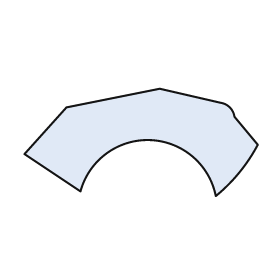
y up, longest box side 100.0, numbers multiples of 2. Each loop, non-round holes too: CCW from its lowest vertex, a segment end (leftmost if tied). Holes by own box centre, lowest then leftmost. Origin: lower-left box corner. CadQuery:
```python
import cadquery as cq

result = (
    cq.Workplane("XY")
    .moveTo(82.0, 0.0)
    .threePointArc((92.0, 10.0), (100.0, 22.0))
    .lineTo(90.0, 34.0)
    .threePointArc((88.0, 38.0), (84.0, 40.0))
    .lineTo(58.0, 46.0)
    .lineTo(18.0, 38.0)
    .lineTo(0.0, 18.0)
    .lineTo(24.0, 2.0)
    .threePointArc((54.0, 24.0), (82.0, 0.0))
    .close()
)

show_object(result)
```